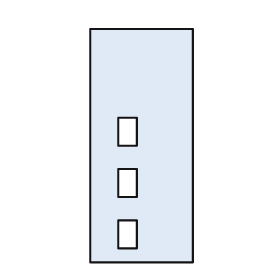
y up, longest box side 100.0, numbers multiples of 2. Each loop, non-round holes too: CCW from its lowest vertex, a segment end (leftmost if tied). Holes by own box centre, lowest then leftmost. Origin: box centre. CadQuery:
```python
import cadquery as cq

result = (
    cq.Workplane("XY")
    .moveTo(-22.0, -50.0)
    .lineTo(22.0, -50.0)
    .lineTo(22.0, 50.0)
    .lineTo(-22.0, 50.0)
    .close()
    .moveTo(-10.0, -44.0)
    .lineTo(-2.0, -44.0)
    .lineTo(-2.0, -32.0)
    .lineTo(-10.0, -32.0)
    .close()
    .moveTo(-10.0, -22.0)
    .lineTo(-2.0, -22.0)
    .lineTo(-2.0, -10.0)
    .lineTo(-10.0, -10.0)
    .close()
    .moveTo(-10.0, 0.0)
    .lineTo(-2.0, 0.0)
    .lineTo(-2.0, 12.0)
    .lineTo(-10.0, 12.0)
    .close()
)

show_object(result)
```